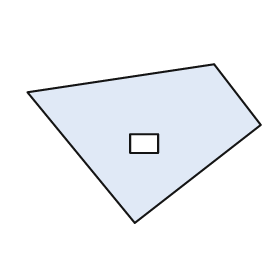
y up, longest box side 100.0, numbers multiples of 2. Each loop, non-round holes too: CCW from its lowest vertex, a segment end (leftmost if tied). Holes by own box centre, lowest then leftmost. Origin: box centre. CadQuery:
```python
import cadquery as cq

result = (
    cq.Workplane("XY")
    .moveTo(-4.0, -34.0)
    .lineTo(50.0, 8.0)
    .lineTo(30.0, 34.0)
    .lineTo(-50.0, 22.0)
    .close()
    .moveTo(-6.0, -4.0)
    .lineTo(6.0, -4.0)
    .lineTo(6.0, 4.0)
    .lineTo(-6.0, 4.0)
    .close()
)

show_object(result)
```